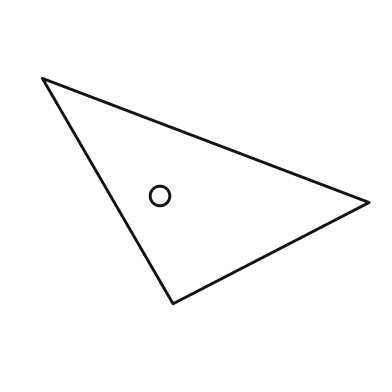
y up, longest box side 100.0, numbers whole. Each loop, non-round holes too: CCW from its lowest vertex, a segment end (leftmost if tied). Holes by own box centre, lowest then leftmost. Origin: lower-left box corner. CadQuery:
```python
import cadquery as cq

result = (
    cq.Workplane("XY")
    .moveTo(40.0, 0.0)
    .lineTo(100.0, 31.0)
    .lineTo(0.0, 69.0)
    .close()
    .moveTo(36.0, 33.0)
    .circle(3.0)
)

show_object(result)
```